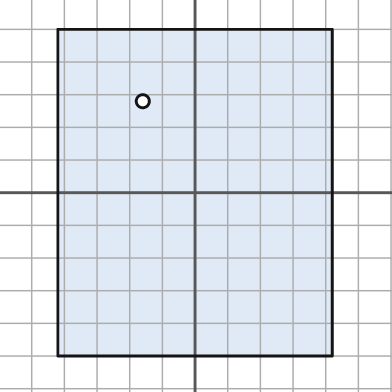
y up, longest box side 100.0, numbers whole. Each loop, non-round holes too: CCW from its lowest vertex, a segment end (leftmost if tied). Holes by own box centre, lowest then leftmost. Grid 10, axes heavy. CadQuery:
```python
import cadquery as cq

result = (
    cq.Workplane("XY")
    .moveTo(-42.0, -50.0)
    .lineTo(42.0, -50.0)
    .lineTo(42.0, 50.0)
    .lineTo(-42.0, 50.0)
    .close()
    .moveTo(-16.0, 28.0)
    .circle(2.0)
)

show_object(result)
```